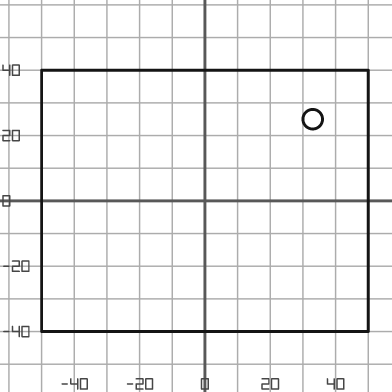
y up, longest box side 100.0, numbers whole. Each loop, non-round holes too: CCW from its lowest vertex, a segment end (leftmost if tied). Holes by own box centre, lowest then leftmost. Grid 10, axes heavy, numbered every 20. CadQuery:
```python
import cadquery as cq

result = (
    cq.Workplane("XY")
    .moveTo(-50.0, -40.0)
    .lineTo(50.0, -40.0)
    .lineTo(50.0, 40.0)
    .lineTo(-50.0, 40.0)
    .close()
    .moveTo(33.0, 25.0)
    .circle(3.0)
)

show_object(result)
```